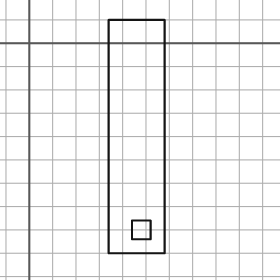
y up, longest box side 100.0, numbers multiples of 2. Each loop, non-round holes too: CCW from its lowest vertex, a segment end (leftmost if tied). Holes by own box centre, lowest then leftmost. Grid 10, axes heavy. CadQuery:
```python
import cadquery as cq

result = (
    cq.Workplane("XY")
    .moveTo(34.0, -90.0)
    .lineTo(58.0, -90.0)
    .lineTo(58.0, 10.0)
    .lineTo(34.0, 10.0)
    .close()
    .moveTo(44.0, -84.0)
    .lineTo(52.0, -84.0)
    .lineTo(52.0, -76.0)
    .lineTo(44.0, -76.0)
    .close()
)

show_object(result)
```